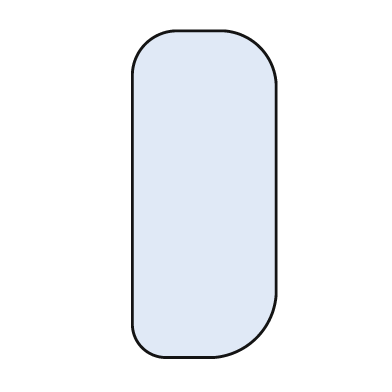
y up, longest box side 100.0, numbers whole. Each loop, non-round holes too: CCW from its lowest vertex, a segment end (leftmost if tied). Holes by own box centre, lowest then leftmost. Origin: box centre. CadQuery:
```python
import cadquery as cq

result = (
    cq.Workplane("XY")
    .moveTo(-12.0, -50.0)
    .lineTo(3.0, -50.0)
    .threePointArc((16.0, -44.0), (22.0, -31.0))
    .lineTo(22.0, 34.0)
    .threePointArc((17.0, 45.0), (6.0, 50.0))
    .lineTo(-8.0, 50.0)
    .threePointArc((-18.0, 46.0), (-22.0, 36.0))
    .lineTo(-22.0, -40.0)
    .threePointArc((-19.0, -47.0), (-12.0, -50.0))
    .close()
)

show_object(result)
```